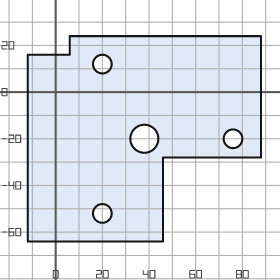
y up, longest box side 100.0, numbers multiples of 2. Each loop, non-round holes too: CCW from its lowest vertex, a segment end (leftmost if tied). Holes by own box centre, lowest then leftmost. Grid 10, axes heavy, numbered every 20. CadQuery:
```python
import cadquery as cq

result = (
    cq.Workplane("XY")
    .moveTo(-12.0, -64.0)
    .lineTo(46.0, -64.0)
    .lineTo(46.0, -28.0)
    .lineTo(88.0, -28.0)
    .lineTo(88.0, 24.0)
    .lineTo(6.0, 24.0)
    .lineTo(6.0, 16.0)
    .lineTo(-12.0, 16.0)
    .close()
    .moveTo(20.0, -52.0)
    .circle(4.0)
    .moveTo(38.0, -20.0)
    .circle(6.0)
    .moveTo(76.0, -20.0)
    .circle(4.0)
    .moveTo(20.0, 12.0)
    .circle(4.0)
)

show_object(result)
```